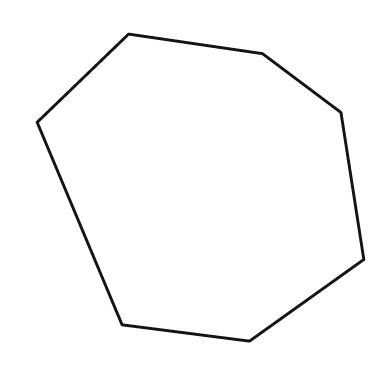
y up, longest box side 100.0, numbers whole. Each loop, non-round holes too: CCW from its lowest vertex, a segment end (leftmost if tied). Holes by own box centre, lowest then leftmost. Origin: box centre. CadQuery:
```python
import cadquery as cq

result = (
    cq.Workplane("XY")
    .moveTo(15.0, -47.0)
    .lineTo(50.0, -22.0)
    .lineTo(43.0, 23.0)
    .lineTo(19.0, 41.0)
    .lineTo(-22.0, 47.0)
    .lineTo(-50.0, 20.0)
    .lineTo(-24.0, -42.0)
    .close()
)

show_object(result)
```